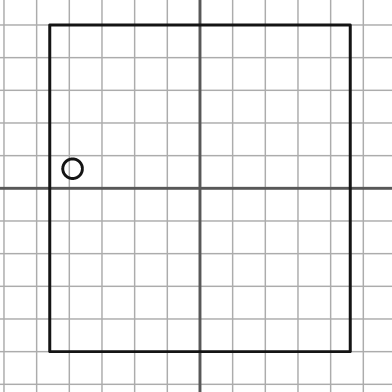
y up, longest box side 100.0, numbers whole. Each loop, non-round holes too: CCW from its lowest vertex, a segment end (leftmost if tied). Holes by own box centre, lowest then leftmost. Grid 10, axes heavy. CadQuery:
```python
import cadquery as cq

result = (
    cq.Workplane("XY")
    .moveTo(-46.0, -50.0)
    .lineTo(46.0, -50.0)
    .lineTo(46.0, 50.0)
    .lineTo(-46.0, 50.0)
    .close()
    .moveTo(-39.0, 6.0)
    .circle(3.0)
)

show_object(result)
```